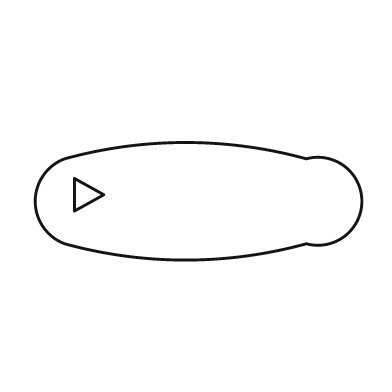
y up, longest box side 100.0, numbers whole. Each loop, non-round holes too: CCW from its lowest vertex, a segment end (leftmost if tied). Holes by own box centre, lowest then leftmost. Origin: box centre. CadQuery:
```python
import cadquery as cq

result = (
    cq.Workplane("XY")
    .moveTo(-41.0, -13.0)
    .threePointArc((-4.0, -18.0), (33.0, -13.0))
    .threePointArc((50.0, 0.0), (33.0, 13.0))
    .threePointArc((-4.0, 18.0), (-41.0, 13.0))
    .threePointArc((-50.0, 0.0), (-41.0, -13.0))
    .close()
    .moveTo(-38.0, -3.0)
    .lineTo(-29.0, 2.0)
    .lineTo(-38.0, 7.0)
    .close()
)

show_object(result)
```